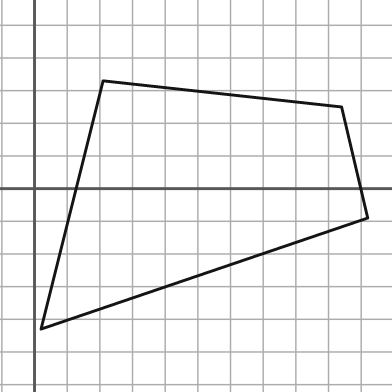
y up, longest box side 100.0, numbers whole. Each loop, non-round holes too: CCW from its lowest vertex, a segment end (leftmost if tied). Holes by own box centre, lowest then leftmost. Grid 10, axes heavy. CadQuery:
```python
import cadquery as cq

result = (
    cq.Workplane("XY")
    .moveTo(2.0, -43.0)
    .lineTo(102.0, -9.0)
    .lineTo(94.0, 25.0)
    .lineTo(21.0, 33.0)
    .close()
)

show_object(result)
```